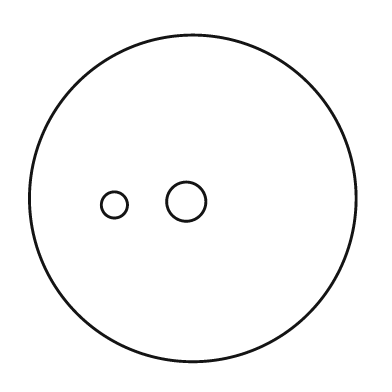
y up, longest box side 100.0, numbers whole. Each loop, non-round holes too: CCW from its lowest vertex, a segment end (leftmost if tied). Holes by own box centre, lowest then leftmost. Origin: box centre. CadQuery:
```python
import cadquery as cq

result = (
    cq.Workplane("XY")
    .moveTo(0.0, 0.0)
    .circle(50.0)
    .moveTo(-24.0, -2.0)
    .circle(4.0)
    .moveTo(-2.0, -1.0)
    .circle(6.0)
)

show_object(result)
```